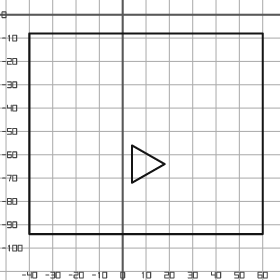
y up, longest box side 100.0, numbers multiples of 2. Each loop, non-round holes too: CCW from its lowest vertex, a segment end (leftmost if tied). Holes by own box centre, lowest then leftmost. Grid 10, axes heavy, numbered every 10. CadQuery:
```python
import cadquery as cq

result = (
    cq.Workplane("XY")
    .moveTo(-40.0, -94.0)
    .lineTo(60.0, -94.0)
    .lineTo(60.0, -8.0)
    .lineTo(-40.0, -8.0)
    .close()
    .moveTo(4.0, -72.0)
    .lineTo(18.0, -64.0)
    .lineTo(4.0, -56.0)
    .close()
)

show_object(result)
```